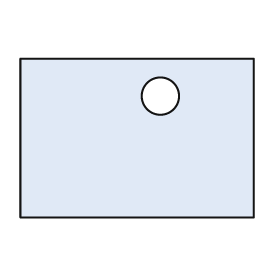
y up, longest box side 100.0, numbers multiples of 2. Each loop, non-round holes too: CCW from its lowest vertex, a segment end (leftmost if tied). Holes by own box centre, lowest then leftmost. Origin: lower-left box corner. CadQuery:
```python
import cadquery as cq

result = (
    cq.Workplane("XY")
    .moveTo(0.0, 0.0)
    .lineTo(100.0, 0.0)
    .lineTo(100.0, 68.0)
    .lineTo(0.0, 68.0)
    .close()
    .moveTo(60.0, 52.0)
    .circle(8.0)
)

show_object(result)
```